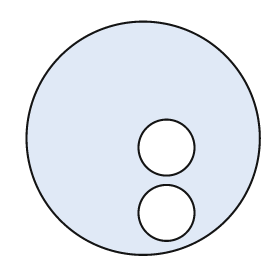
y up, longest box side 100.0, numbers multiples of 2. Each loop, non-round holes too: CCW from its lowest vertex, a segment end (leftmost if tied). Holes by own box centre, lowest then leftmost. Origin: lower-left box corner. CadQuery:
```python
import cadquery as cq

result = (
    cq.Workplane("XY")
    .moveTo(50.0, 50.0)
    .circle(50.0)
    .moveTo(60.0, 18.0)
    .circle(12.0)
    .moveTo(60.0, 46.0)
    .circle(12.0)
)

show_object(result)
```